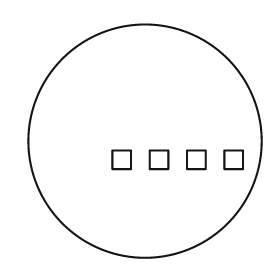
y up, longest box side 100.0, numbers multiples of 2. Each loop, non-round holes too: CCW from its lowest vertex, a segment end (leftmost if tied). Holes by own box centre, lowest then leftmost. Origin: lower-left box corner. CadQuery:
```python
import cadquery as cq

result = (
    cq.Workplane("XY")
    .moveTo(50.0, 50.0)
    .circle(50.0)
    .moveTo(36.0, 38.0)
    .lineTo(44.0, 38.0)
    .lineTo(44.0, 46.0)
    .lineTo(36.0, 46.0)
    .close()
    .moveTo(52.0, 38.0)
    .lineTo(60.0, 38.0)
    .lineTo(60.0, 46.0)
    .lineTo(52.0, 46.0)
    .close()
    .moveTo(68.0, 38.0)
    .lineTo(76.0, 38.0)
    .lineTo(76.0, 46.0)
    .lineTo(68.0, 46.0)
    .close()
    .moveTo(84.0, 38.0)
    .lineTo(92.0, 38.0)
    .lineTo(92.0, 46.0)
    .lineTo(84.0, 46.0)
    .close()
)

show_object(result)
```